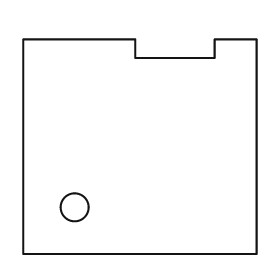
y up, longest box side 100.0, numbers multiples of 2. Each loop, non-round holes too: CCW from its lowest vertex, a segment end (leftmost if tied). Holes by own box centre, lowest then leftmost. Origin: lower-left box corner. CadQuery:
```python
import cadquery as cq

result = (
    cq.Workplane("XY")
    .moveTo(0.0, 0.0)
    .lineTo(100.0, 0.0)
    .lineTo(100.0, 92.0)
    .lineTo(82.0, 92.0)
    .lineTo(82.0, 84.0)
    .lineTo(48.0, 84.0)
    .lineTo(48.0, 92.0)
    .lineTo(0.0, 92.0)
    .close()
    .moveTo(22.0, 20.0)
    .circle(6.0)
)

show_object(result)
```